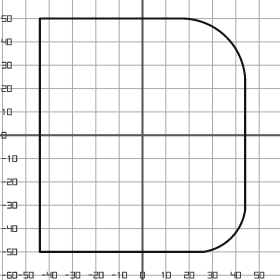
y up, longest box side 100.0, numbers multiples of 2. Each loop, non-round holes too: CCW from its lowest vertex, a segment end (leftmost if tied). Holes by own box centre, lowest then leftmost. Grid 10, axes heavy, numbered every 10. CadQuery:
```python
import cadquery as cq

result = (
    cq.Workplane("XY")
    .moveTo(-44.0, -50.0)
    .lineTo(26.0, -50.0)
    .threePointArc((38.0, -44.0), (44.0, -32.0))
    .lineTo(44.0, 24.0)
    .threePointArc((36.0, 42.0), (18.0, 50.0))
    .lineTo(-44.0, 50.0)
    .close()
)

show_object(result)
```